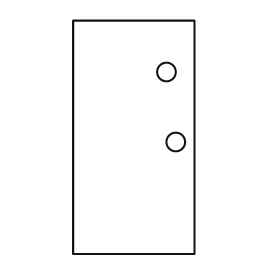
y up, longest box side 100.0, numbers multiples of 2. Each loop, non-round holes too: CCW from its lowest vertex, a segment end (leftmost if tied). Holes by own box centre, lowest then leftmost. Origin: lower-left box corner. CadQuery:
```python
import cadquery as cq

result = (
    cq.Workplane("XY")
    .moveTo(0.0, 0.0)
    .lineTo(52.0, 0.0)
    .lineTo(52.0, 100.0)
    .lineTo(0.0, 100.0)
    .close()
    .moveTo(44.0, 48.0)
    .circle(4.0)
    .moveTo(40.0, 78.0)
    .circle(4.0)
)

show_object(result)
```